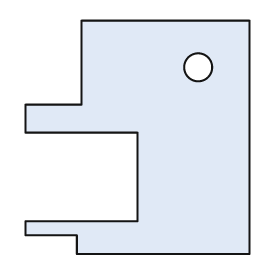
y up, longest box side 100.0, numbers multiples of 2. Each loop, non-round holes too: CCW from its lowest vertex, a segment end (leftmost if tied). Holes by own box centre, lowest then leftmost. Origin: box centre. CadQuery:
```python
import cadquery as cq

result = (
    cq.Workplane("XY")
    .moveTo(-26.0, -50.0)
    .lineTo(48.0, -50.0)
    .lineTo(48.0, 50.0)
    .lineTo(-24.0, 50.0)
    .lineTo(-24.0, 14.0)
    .lineTo(-48.0, 14.0)
    .lineTo(-48.0, 2.0)
    .lineTo(0.0, 2.0)
    .lineTo(0.0, -36.0)
    .lineTo(-48.0, -36.0)
    .lineTo(-48.0, -42.0)
    .lineTo(-26.0, -42.0)
    .close()
    .moveTo(26.0, 30.0)
    .circle(6.0)
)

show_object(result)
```